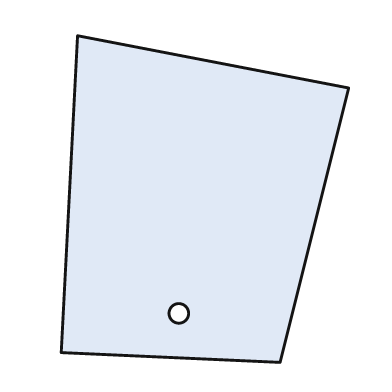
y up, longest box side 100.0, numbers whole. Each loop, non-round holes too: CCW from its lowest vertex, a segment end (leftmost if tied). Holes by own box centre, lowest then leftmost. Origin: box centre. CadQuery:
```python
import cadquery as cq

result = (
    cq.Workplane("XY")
    .moveTo(23.0, -50.0)
    .lineTo(44.0, 34.0)
    .lineTo(-39.0, 50.0)
    .lineTo(-44.0, -47.0)
    .close()
    .moveTo(-8.0, -35.0)
    .circle(3.0)
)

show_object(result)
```